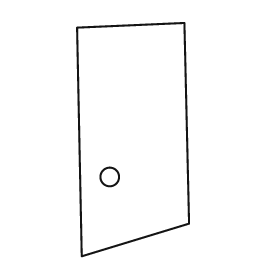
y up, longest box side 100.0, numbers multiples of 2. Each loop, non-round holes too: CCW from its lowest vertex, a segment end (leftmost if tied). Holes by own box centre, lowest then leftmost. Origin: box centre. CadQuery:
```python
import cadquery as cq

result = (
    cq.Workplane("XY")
    .moveTo(-22.0, -50.0)
    .lineTo(24.0, -36.0)
    .lineTo(22.0, 50.0)
    .lineTo(-24.0, 48.0)
    .close()
    .moveTo(-10.0, -16.0)
    .circle(4.0)
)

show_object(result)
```